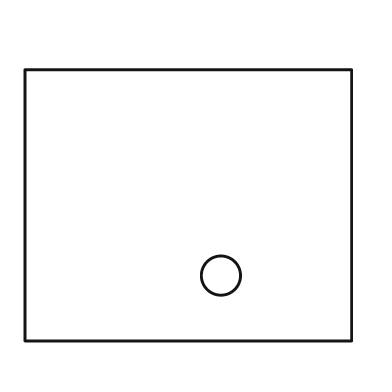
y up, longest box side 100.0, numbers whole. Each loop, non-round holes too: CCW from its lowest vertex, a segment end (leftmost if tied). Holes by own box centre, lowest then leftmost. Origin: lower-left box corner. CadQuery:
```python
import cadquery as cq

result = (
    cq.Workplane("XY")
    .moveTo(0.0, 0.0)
    .lineTo(100.0, 0.0)
    .lineTo(100.0, 83.0)
    .lineTo(0.0, 83.0)
    .close()
    .moveTo(60.0, 20.0)
    .circle(6.0)
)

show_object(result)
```